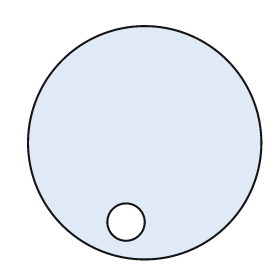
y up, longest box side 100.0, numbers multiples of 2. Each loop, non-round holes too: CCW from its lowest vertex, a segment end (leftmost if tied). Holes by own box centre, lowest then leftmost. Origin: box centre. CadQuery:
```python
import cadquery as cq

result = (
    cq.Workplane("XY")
    .moveTo(0.0, 0.0)
    .circle(50.0)
    .moveTo(-8.0, -34.0)
    .circle(8.0)
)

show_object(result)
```